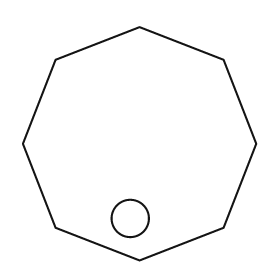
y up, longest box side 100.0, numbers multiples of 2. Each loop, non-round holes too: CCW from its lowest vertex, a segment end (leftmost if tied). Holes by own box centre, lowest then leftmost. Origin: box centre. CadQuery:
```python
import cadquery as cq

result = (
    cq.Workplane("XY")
    .moveTo(0.0, -50.0)
    .lineTo(36.0, -36.0)
    .lineTo(50.0, 0.0)
    .lineTo(36.0, 36.0)
    .lineTo(0.0, 50.0)
    .lineTo(-36.0, 36.0)
    .lineTo(-50.0, 0.0)
    .lineTo(-36.0, -36.0)
    .close()
    .moveTo(-4.0, -32.0)
    .circle(8.0)
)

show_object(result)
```